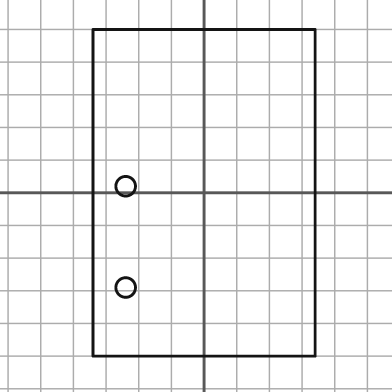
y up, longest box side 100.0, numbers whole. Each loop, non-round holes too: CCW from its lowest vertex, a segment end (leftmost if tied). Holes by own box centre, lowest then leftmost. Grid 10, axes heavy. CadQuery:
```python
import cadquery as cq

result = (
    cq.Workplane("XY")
    .moveTo(-34.0, -50.0)
    .lineTo(34.0, -50.0)
    .lineTo(34.0, 50.0)
    .lineTo(-34.0, 50.0)
    .close()
    .moveTo(-24.0, -29.0)
    .circle(3.0)
    .moveTo(-24.0, 2.0)
    .circle(3.0)
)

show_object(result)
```